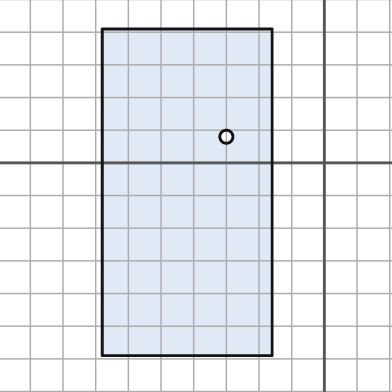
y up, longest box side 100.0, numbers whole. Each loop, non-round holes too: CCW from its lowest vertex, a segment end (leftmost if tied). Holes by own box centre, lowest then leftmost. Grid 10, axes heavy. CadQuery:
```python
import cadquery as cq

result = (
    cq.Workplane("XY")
    .moveTo(-68.0, -59.0)
    .lineTo(-16.0, -59.0)
    .lineTo(-16.0, 41.0)
    .lineTo(-68.0, 41.0)
    .close()
    .moveTo(-30.0, 8.0)
    .circle(2.0)
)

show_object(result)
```